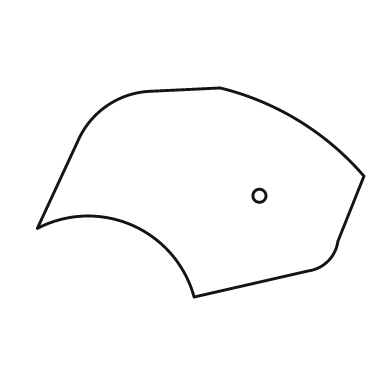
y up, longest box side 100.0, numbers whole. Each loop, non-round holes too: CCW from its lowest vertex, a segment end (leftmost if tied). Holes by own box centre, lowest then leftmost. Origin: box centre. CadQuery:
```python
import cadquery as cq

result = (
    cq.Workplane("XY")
    .moveTo(-2.0, -32.0)
    .lineTo(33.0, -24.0)
    .threePointArc((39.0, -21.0), (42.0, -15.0))
    .lineTo(50.0, 5.0)
    .threePointArc((30.0, 22.0), (6.0, 32.0))
    .lineTo(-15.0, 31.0)
    .threePointArc((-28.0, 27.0), (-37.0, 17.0))
    .lineTo(-50.0, -11.0)
    .threePointArc((-21.0, -10.0), (-2.0, -32.0))
    .close()
    .moveTo(18.0, -1.0)
    .circle(2.0)
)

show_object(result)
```